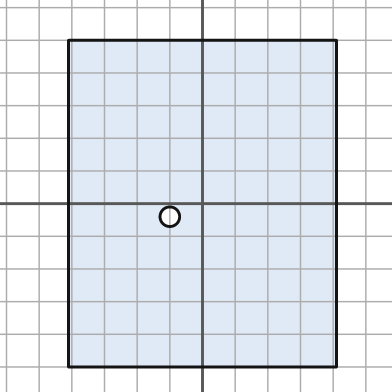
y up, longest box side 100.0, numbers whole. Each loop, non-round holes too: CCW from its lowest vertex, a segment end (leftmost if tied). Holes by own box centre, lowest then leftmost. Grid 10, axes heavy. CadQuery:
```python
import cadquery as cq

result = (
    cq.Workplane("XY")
    .moveTo(-41.0, -50.0)
    .lineTo(41.0, -50.0)
    .lineTo(41.0, 50.0)
    .lineTo(-41.0, 50.0)
    .close()
    .moveTo(-10.0, -4.0)
    .circle(3.0)
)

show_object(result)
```